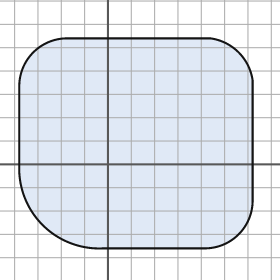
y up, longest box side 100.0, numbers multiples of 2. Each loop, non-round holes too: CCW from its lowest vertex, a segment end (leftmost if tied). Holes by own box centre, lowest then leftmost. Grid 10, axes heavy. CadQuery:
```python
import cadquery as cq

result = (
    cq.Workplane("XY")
    .moveTo(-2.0, -36.0)
    .lineTo(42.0, -36.0)
    .threePointArc((56.0, -30.0), (62.0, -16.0))
    .lineTo(62.0, 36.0)
    .threePointArc((56.0, 48.0), (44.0, 54.0))
    .lineTo(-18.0, 54.0)
    .threePointArc((-32.0, 48.0), (-38.0, 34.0))
    .lineTo(-38.0, 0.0)
    .threePointArc((-28.0, -26.0), (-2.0, -36.0))
    .close()
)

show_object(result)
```